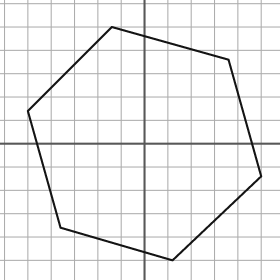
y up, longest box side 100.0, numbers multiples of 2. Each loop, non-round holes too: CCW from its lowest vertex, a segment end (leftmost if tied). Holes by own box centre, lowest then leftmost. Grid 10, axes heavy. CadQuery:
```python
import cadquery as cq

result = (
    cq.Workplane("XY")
    .moveTo(12.0, -50.0)
    .lineTo(50.0, -14.0)
    .lineTo(36.0, 36.0)
    .lineTo(-14.0, 50.0)
    .lineTo(-50.0, 14.0)
    .lineTo(-36.0, -36.0)
    .close()
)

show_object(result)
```